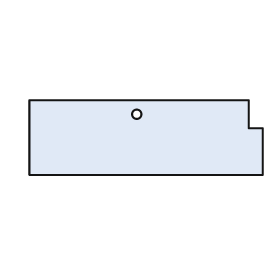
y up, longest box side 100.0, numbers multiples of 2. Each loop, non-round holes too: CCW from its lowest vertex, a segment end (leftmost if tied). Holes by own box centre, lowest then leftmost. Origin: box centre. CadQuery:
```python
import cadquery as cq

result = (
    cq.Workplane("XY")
    .moveTo(-50.0, -16.0)
    .lineTo(50.0, -16.0)
    .lineTo(50.0, 4.0)
    .lineTo(44.0, 4.0)
    .lineTo(44.0, 16.0)
    .lineTo(-50.0, 16.0)
    .close()
    .moveTo(-4.0, 10.0)
    .circle(2.0)
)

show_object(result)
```